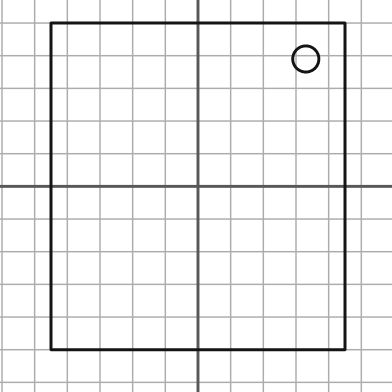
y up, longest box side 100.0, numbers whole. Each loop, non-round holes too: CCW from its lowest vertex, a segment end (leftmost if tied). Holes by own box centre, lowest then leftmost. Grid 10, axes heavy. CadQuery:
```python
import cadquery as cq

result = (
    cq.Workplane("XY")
    .moveTo(-45.0, -50.0)
    .lineTo(45.0, -50.0)
    .lineTo(45.0, 50.0)
    .lineTo(-45.0, 50.0)
    .close()
    .moveTo(33.0, 39.0)
    .circle(4.0)
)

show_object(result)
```